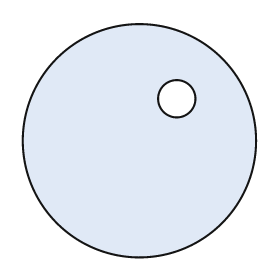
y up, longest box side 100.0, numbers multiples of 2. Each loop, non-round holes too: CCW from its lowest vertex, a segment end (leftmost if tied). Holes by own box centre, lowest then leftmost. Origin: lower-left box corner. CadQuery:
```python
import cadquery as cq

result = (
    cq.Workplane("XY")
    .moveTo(50.0, 50.0)
    .circle(50.0)
    .moveTo(66.0, 68.0)
    .circle(8.0)
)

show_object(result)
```